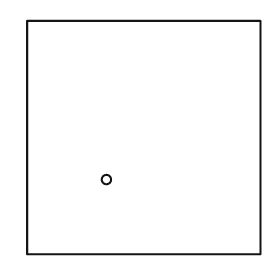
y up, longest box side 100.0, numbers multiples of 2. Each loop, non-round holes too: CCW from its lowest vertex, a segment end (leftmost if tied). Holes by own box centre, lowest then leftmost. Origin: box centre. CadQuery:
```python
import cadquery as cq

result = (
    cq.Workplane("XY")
    .moveTo(-50.0, -50.0)
    .lineTo(50.0, -50.0)
    .lineTo(50.0, 50.0)
    .lineTo(-50.0, 50.0)
    .close()
    .moveTo(-16.0, -18.0)
    .circle(2.0)
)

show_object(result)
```